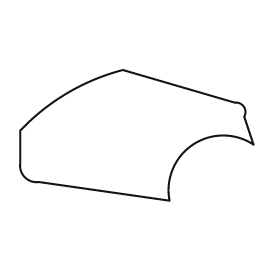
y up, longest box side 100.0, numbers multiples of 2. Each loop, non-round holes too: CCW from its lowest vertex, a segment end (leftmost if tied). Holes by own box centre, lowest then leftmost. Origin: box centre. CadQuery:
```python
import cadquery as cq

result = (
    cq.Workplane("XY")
    .moveTo(14.0, -28.0)
    .threePointArc((24.0, -4.0), (50.0, -4.0))
    .lineTo(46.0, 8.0)
    .threePointArc((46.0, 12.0), (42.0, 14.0))
    .lineTo(-6.0, 28.0)
    .threePointArc((-30.0, 18.0), (-50.0, 2.0))
    .lineTo(-50.0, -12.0)
    .threePointArc((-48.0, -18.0), (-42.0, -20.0))
    .close()
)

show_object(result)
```